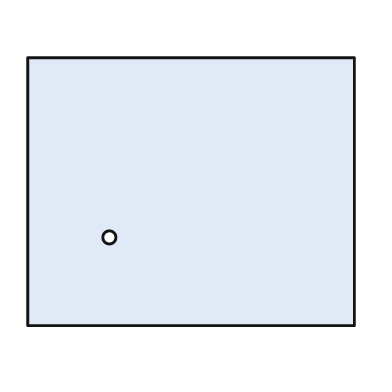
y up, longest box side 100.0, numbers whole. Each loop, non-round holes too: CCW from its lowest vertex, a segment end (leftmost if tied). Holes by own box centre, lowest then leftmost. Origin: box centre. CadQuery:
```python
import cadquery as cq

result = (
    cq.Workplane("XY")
    .moveTo(-50.0, -41.0)
    .lineTo(50.0, -41.0)
    .lineTo(50.0, 41.0)
    .lineTo(-50.0, 41.0)
    .close()
    .moveTo(-25.0, -14.0)
    .circle(2.0)
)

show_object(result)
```